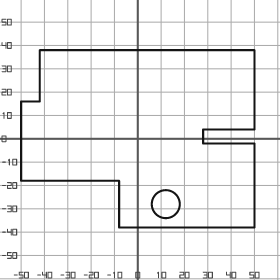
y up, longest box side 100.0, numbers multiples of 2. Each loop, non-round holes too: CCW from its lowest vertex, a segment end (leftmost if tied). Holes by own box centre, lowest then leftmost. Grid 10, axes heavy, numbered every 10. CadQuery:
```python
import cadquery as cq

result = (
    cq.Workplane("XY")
    .moveTo(-8.0, -38.0)
    .lineTo(50.0, -38.0)
    .lineTo(50.0, -2.0)
    .lineTo(28.0, -2.0)
    .lineTo(28.0, 4.0)
    .lineTo(50.0, 4.0)
    .lineTo(50.0, 38.0)
    .lineTo(-42.0, 38.0)
    .lineTo(-42.0, 16.0)
    .lineTo(-50.0, 16.0)
    .lineTo(-50.0, -18.0)
    .lineTo(-8.0, -18.0)
    .close()
    .moveTo(12.0, -28.0)
    .circle(6.0)
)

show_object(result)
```